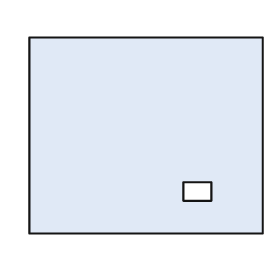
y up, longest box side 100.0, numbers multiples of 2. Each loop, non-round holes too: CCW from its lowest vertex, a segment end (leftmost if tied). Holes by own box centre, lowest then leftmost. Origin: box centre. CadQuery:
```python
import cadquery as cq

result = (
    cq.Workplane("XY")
    .moveTo(-50.0, -42.0)
    .lineTo(50.0, -42.0)
    .lineTo(50.0, 42.0)
    .lineTo(-50.0, 42.0)
    .close()
    .moveTo(16.0, -28.0)
    .lineTo(28.0, -28.0)
    .lineTo(28.0, -20.0)
    .lineTo(16.0, -20.0)
    .close()
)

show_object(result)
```